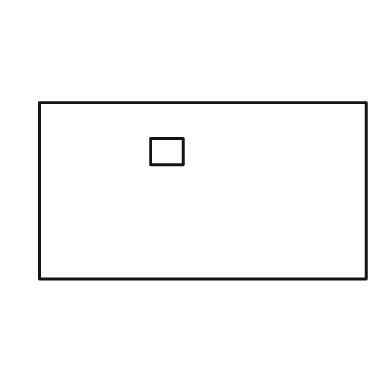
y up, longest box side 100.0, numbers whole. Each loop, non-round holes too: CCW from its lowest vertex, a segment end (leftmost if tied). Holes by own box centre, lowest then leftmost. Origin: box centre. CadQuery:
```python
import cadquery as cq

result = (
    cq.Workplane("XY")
    .moveTo(-50.0, -27.0)
    .lineTo(50.0, -27.0)
    .lineTo(50.0, 27.0)
    .lineTo(-50.0, 27.0)
    .close()
    .moveTo(-16.0, 8.0)
    .lineTo(-6.0, 8.0)
    .lineTo(-6.0, 16.0)
    .lineTo(-16.0, 16.0)
    .close()
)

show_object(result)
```